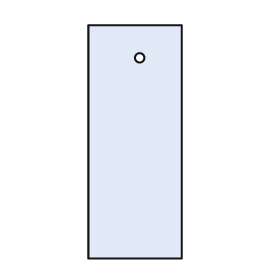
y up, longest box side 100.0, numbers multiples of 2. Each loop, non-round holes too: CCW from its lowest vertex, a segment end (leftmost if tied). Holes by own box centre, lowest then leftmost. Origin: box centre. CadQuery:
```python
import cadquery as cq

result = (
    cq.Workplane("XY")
    .moveTo(-20.0, -50.0)
    .lineTo(20.0, -50.0)
    .lineTo(20.0, 50.0)
    .lineTo(-20.0, 50.0)
    .close()
    .moveTo(2.0, 36.0)
    .circle(2.0)
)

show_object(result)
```